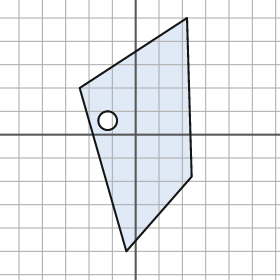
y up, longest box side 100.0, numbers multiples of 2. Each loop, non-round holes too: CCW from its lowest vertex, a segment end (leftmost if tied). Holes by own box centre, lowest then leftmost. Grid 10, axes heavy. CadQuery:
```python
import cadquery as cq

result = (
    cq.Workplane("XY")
    .moveTo(-4.0, -50.0)
    .lineTo(24.0, -18.0)
    .lineTo(22.0, 50.0)
    .lineTo(-24.0, 20.0)
    .close()
    .moveTo(-12.0, 6.0)
    .circle(4.0)
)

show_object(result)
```